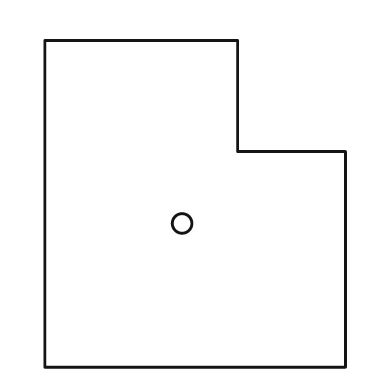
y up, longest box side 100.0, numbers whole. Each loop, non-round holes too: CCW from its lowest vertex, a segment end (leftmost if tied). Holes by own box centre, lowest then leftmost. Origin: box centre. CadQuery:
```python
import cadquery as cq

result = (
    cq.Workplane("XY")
    .moveTo(-46.0, -50.0)
    .lineTo(46.0, -50.0)
    .lineTo(46.0, 16.0)
    .lineTo(13.0, 16.0)
    .lineTo(13.0, 50.0)
    .lineTo(-46.0, 50.0)
    .close()
    .moveTo(-4.0, -6.0)
    .circle(3.0)
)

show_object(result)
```